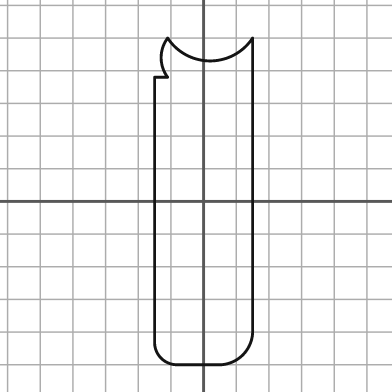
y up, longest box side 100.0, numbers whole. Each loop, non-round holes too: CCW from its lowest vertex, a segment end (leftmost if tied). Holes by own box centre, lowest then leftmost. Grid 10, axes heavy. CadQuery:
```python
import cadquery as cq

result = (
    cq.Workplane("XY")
    .moveTo(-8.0, -50.0)
    .lineTo(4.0, -50.0)
    .threePointArc((12.0, -47.0), (15.0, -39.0))
    .lineTo(15.0, 50.0)
    .threePointArc((2.0, 43.0), (-11.0, 50.0))
    .threePointArc((-13.0, 44.0), (-11.0, 38.0))
    .lineTo(-15.0, 38.0)
    .lineTo(-15.0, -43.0)
    .threePointArc((-13.0, -48.0), (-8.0, -50.0))
    .close()
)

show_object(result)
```